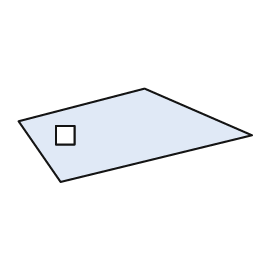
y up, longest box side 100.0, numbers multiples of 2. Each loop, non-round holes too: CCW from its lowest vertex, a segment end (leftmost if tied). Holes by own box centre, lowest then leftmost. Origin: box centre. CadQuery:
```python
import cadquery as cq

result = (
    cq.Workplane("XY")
    .moveTo(-32.0, -20.0)
    .lineTo(50.0, 0.0)
    .lineTo(4.0, 20.0)
    .lineTo(-50.0, 6.0)
    .close()
    .moveTo(-34.0, -4.0)
    .lineTo(-26.0, -4.0)
    .lineTo(-26.0, 4.0)
    .lineTo(-34.0, 4.0)
    .close()
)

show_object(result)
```